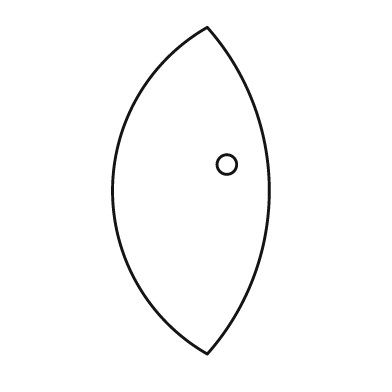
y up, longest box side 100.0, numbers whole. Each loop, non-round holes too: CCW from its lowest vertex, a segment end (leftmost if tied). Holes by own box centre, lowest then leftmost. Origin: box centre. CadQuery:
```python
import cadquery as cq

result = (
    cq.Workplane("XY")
    .moveTo(5.0, -50.0)
    .threePointArc((24.0, 0.0), (5.0, 50.0))
    .threePointArc((-24.0, 0.0), (5.0, -50.0))
    .close()
    .moveTo(11.0, 8.0)
    .circle(3.0)
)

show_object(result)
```